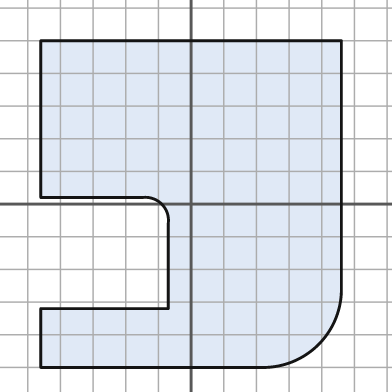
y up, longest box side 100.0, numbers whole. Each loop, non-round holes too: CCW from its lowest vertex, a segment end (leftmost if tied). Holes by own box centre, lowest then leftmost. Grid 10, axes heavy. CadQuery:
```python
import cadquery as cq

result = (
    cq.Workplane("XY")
    .moveTo(-46.0, -50.0)
    .lineTo(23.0, -50.0)
    .threePointArc((39.0, -43.0), (46.0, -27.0))
    .lineTo(46.0, 50.0)
    .lineTo(-46.0, 50.0)
    .lineTo(-46.0, 2.0)
    .lineTo(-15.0, 2.0)
    .threePointArc((-9.0, 0.0), (-7.0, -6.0))
    .lineTo(-7.0, -32.0)
    .lineTo(-46.0, -32.0)
    .close()
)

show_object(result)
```